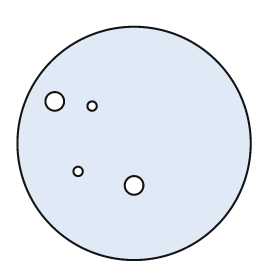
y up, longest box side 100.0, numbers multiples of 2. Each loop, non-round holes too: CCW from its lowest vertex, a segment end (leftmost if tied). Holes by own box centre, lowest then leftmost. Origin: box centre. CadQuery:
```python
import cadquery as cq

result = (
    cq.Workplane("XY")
    .moveTo(0.0, 0.0)
    .circle(50.0)
    .moveTo(0.0, -18.0)
    .circle(4.0)
    .moveTo(-24.0, -12.0)
    .circle(2.0)
    .moveTo(-18.0, 16.0)
    .circle(2.0)
    .moveTo(-34.0, 18.0)
    .circle(4.0)
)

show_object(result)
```